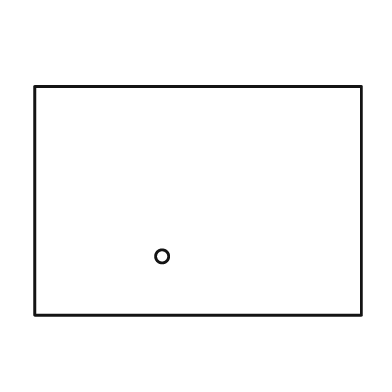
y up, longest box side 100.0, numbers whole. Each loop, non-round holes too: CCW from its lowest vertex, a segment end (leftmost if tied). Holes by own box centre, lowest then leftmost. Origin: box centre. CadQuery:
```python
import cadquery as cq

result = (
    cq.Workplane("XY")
    .moveTo(-50.0, -35.0)
    .lineTo(50.0, -35.0)
    .lineTo(50.0, 35.0)
    .lineTo(-50.0, 35.0)
    .close()
    .moveTo(-11.0, -17.0)
    .circle(2.0)
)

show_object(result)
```